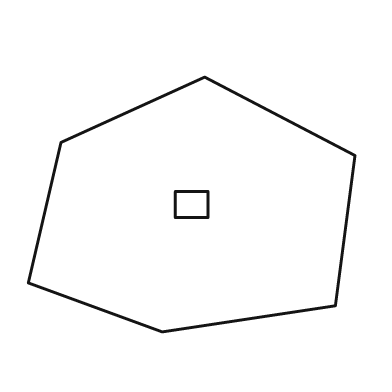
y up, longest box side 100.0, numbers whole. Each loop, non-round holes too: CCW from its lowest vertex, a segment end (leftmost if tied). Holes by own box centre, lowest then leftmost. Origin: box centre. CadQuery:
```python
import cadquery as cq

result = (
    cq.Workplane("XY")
    .moveTo(-9.0, -39.0)
    .lineTo(44.0, -31.0)
    .lineTo(50.0, 15.0)
    .lineTo(4.0, 39.0)
    .lineTo(-40.0, 19.0)
    .lineTo(-50.0, -24.0)
    .close()
    .moveTo(-5.0, -4.0)
    .lineTo(5.0, -4.0)
    .lineTo(5.0, 4.0)
    .lineTo(-5.0, 4.0)
    .close()
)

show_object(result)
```